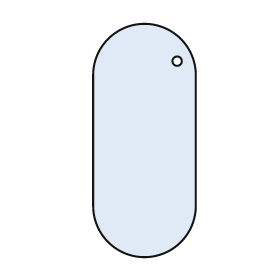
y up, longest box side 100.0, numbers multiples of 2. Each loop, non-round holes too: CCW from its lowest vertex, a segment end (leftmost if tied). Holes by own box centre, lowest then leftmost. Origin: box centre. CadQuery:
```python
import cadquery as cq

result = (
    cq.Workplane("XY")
    .moveTo(-22.0, -28.0)
    .threePointArc((0.0, -50.0), (22.0, -28.0))
    .lineTo(22.0, 28.0)
    .threePointArc((0.0, 50.0), (-22.0, 28.0))
    .close()
    .moveTo(14.0, 34.0)
    .circle(2.0)
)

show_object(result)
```